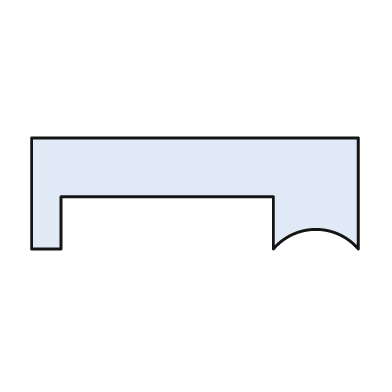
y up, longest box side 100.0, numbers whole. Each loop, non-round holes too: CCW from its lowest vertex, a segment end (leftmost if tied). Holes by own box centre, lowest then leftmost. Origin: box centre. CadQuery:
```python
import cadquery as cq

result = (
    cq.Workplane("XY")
    .moveTo(-50.0, -17.0)
    .lineTo(-41.0, -17.0)
    .lineTo(-41.0, -1.0)
    .lineTo(24.0, -1.0)
    .lineTo(24.0, -17.0)
    .threePointArc((37.0, -11.0), (50.0, -17.0))
    .lineTo(50.0, 17.0)
    .lineTo(-50.0, 17.0)
    .close()
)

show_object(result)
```